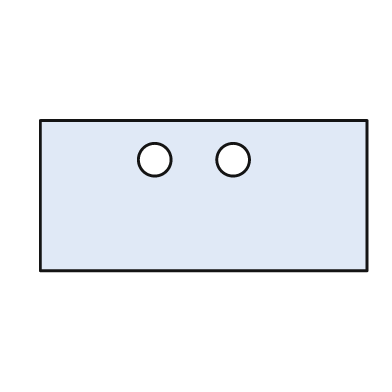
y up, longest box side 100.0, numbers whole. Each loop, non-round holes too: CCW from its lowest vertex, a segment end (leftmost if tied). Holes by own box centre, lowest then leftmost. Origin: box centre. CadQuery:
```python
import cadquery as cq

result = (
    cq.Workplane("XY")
    .moveTo(-50.0, -23.0)
    .lineTo(50.0, -23.0)
    .lineTo(50.0, 23.0)
    .lineTo(-50.0, 23.0)
    .close()
    .moveTo(-15.0, 11.0)
    .circle(5.0)
    .moveTo(9.0, 11.0)
    .circle(5.0)
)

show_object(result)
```